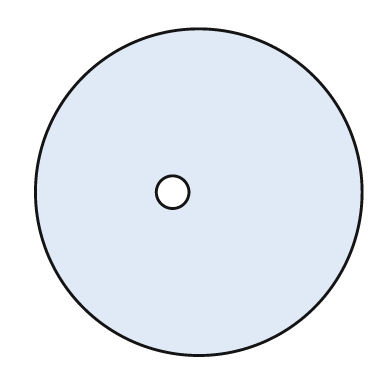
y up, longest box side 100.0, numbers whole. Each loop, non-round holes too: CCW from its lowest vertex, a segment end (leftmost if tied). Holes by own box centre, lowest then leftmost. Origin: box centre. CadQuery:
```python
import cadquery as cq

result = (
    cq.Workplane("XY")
    .moveTo(0.0, 0.0)
    .circle(50.0)
    .moveTo(-8.0, 0.0)
    .circle(5.0)
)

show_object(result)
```